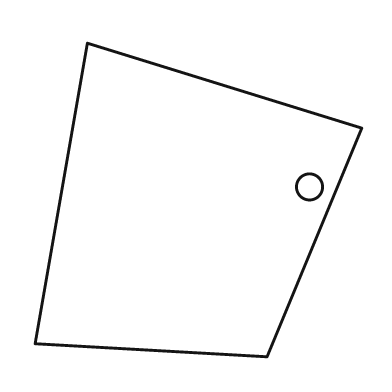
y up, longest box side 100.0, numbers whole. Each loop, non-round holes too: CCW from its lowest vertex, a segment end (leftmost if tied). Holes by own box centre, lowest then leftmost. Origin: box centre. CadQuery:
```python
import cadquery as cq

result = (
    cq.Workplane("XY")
    .moveTo(21.0, -48.0)
    .lineTo(50.0, 22.0)
    .lineTo(-34.0, 48.0)
    .lineTo(-50.0, -44.0)
    .close()
    .moveTo(34.0, 4.0)
    .circle(4.0)
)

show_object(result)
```